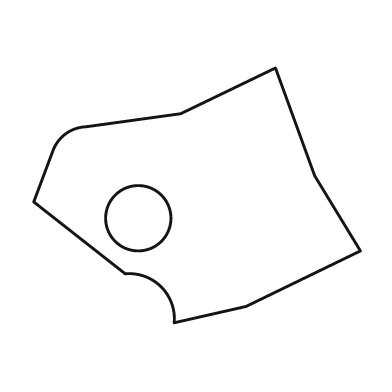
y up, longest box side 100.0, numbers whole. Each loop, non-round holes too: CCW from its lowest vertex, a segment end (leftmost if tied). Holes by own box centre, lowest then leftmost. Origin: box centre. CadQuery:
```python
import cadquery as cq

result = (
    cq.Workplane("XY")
    .moveTo(-7.0, -39.0)
    .lineTo(15.0, -34.0)
    .lineTo(50.0, -17.0)
    .lineTo(36.0, 6.0)
    .lineTo(24.0, 39.0)
    .lineTo(-5.0, 25.0)
    .lineTo(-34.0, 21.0)
    .threePointArc((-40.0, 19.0), (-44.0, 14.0))
    .lineTo(-50.0, -2.0)
    .lineTo(-22.0, -24.0)
    .threePointArc((-11.0, -28.0), (-7.0, -39.0))
    .close()
    .moveTo(-18.0, -7.0)
    .circle(10.0)
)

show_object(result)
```